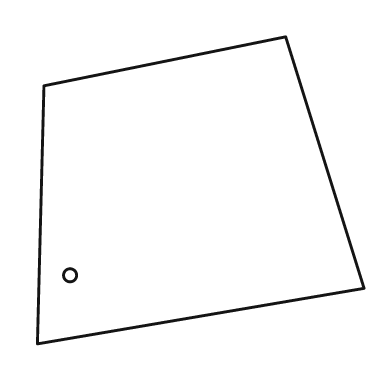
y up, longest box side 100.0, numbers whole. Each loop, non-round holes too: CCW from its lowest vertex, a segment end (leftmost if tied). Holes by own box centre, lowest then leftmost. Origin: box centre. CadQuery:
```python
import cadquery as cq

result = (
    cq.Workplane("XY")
    .moveTo(-50.0, -47.0)
    .lineTo(50.0, -30.0)
    .lineTo(26.0, 47.0)
    .lineTo(-48.0, 32.0)
    .close()
    .moveTo(-40.0, -26.0)
    .circle(2.0)
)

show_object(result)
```